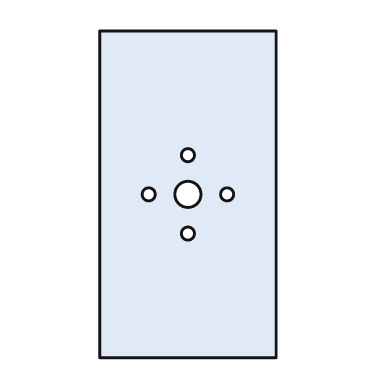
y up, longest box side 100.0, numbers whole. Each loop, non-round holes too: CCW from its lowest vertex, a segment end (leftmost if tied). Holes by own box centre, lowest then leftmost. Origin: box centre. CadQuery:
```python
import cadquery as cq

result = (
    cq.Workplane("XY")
    .moveTo(-27.0, -50.0)
    .lineTo(27.0, -50.0)
    .lineTo(27.0, 50.0)
    .lineTo(-27.0, 50.0)
    .close()
    .moveTo(0.0, -12.0)
    .circle(2.0)
    .moveTo(-12.0, 0.0)
    .circle(2.0)
    .moveTo(0.0, 0.0)
    .circle(4.0)
    .moveTo(12.0, 0.0)
    .circle(2.0)
    .moveTo(0.0, 12.0)
    .circle(2.0)
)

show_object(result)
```